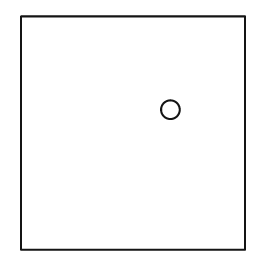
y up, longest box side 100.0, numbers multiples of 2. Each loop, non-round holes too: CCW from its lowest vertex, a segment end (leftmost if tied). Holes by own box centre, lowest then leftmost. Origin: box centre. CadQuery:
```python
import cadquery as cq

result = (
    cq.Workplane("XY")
    .moveTo(-48.0, -50.0)
    .lineTo(48.0, -50.0)
    .lineTo(48.0, 50.0)
    .lineTo(-48.0, 50.0)
    .close()
    .moveTo(16.0, 10.0)
    .circle(4.0)
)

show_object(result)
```